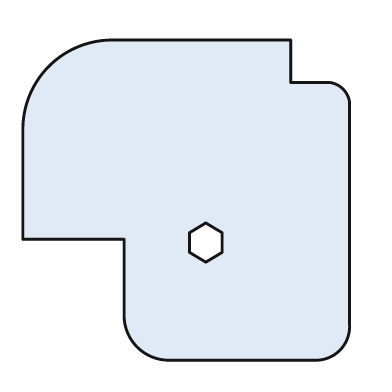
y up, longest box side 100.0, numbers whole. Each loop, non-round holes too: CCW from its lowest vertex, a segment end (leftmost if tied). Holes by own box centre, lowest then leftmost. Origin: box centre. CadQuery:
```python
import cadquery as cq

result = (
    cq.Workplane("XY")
    .moveTo(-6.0, -49.0)
    .lineTo(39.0, -49.0)
    .threePointArc((47.0, -46.0), (50.0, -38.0))
    .lineTo(50.0, 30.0)
    .threePointArc((48.0, 34.0), (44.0, 36.0))
    .lineTo(32.0, 36.0)
    .lineTo(32.0, 49.0)
    .lineTo(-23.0, 49.0)
    .threePointArc((-42.0, 41.0), (-50.0, 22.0))
    .lineTo(-50.0, -12.0)
    .lineTo(-19.0, -12.0)
    .lineTo(-19.0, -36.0)
    .threePointArc((-15.0, -45.0), (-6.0, -49.0))
    .close()
    .moveTo(6.0, -19.0)
    .lineTo(11.0, -16.0)
    .lineTo(11.0, -10.0)
    .lineTo(6.0, -7.0)
    .lineTo(1.0, -10.0)
    .lineTo(1.0, -16.0)
    .close()
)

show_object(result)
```